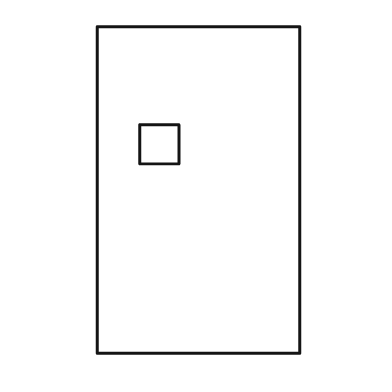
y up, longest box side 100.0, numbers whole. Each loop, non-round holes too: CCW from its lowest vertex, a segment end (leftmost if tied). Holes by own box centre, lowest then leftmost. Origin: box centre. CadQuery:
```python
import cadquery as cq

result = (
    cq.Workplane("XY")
    .moveTo(-31.0, -50.0)
    .lineTo(31.0, -50.0)
    .lineTo(31.0, 50.0)
    .lineTo(-31.0, 50.0)
    .close()
    .moveTo(-18.0, 8.0)
    .lineTo(-6.0, 8.0)
    .lineTo(-6.0, 20.0)
    .lineTo(-18.0, 20.0)
    .close()
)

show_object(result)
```